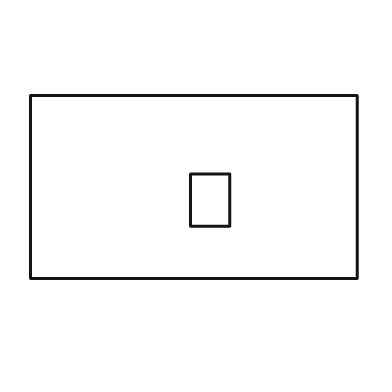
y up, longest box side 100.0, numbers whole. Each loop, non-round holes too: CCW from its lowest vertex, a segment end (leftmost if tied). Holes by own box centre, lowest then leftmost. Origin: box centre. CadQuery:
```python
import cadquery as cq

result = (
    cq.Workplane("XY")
    .moveTo(-50.0, -28.0)
    .lineTo(50.0, -28.0)
    .lineTo(50.0, 28.0)
    .lineTo(-50.0, 28.0)
    .close()
    .moveTo(-1.0, -12.0)
    .lineTo(11.0, -12.0)
    .lineTo(11.0, 4.0)
    .lineTo(-1.0, 4.0)
    .close()
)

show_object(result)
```